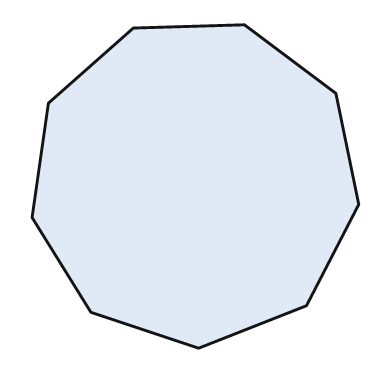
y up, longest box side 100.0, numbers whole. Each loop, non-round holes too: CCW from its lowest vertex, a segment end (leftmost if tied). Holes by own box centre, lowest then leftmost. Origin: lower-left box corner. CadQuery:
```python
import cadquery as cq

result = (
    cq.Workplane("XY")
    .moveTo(51.0, 0.0)
    .lineTo(84.0, 13.0)
    .lineTo(100.0, 44.0)
    .lineTo(93.0, 78.0)
    .lineTo(65.0, 99.0)
    .lineTo(31.0, 98.0)
    .lineTo(5.0, 75.0)
    .lineTo(0.0, 40.0)
    .lineTo(18.0, 11.0)
    .close()
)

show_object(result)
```